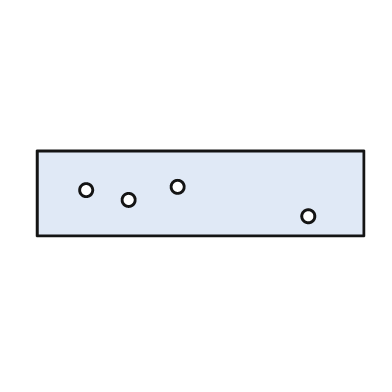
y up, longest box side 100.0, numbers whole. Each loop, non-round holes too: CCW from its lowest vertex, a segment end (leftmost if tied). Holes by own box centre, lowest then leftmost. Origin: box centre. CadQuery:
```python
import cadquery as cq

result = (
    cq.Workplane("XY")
    .moveTo(-50.0, -13.0)
    .lineTo(50.0, -13.0)
    .lineTo(50.0, 13.0)
    .lineTo(-50.0, 13.0)
    .close()
    .moveTo(33.0, -7.0)
    .circle(2.0)
    .moveTo(-22.0, -2.0)
    .circle(2.0)
    .moveTo(-35.0, 1.0)
    .circle(2.0)
    .moveTo(-7.0, 2.0)
    .circle(2.0)
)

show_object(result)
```